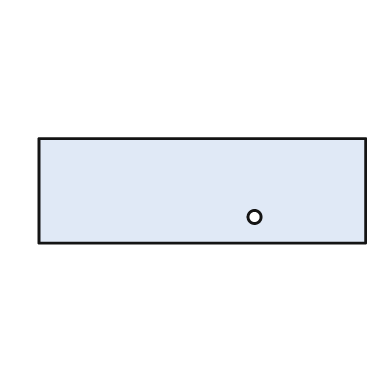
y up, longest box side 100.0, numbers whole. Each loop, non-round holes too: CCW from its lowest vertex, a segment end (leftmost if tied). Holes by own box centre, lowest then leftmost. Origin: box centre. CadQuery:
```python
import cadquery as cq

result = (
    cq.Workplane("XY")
    .moveTo(-50.0, -16.0)
    .lineTo(50.0, -16.0)
    .lineTo(50.0, 16.0)
    .lineTo(-50.0, 16.0)
    .close()
    .moveTo(16.0, -8.0)
    .circle(2.0)
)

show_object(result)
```